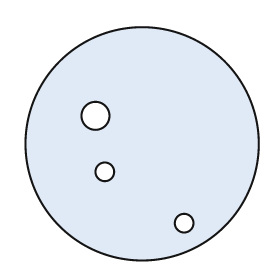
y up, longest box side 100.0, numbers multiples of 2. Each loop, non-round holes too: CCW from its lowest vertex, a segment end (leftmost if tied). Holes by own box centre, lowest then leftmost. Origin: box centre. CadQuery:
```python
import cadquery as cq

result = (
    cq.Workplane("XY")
    .moveTo(0.0, 0.0)
    .circle(50.0)
    .moveTo(18.0, -34.0)
    .circle(4.0)
    .moveTo(-16.0, -12.0)
    .circle(4.0)
    .moveTo(-20.0, 12.0)
    .circle(6.0)
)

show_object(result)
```